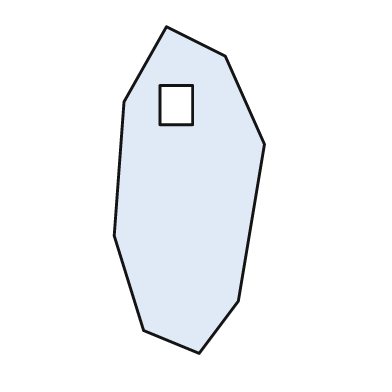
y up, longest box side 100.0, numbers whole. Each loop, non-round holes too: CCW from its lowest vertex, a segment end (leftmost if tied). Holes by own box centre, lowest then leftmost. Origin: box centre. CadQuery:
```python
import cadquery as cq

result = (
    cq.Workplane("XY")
    .moveTo(3.0, -50.0)
    .lineTo(15.0, -34.0)
    .lineTo(23.0, 14.0)
    .lineTo(11.0, 41.0)
    .lineTo(-7.0, 50.0)
    .lineTo(-20.0, 27.0)
    .lineTo(-23.0, -14.0)
    .lineTo(-14.0, -43.0)
    .close()
    .moveTo(-9.0, 20.0)
    .lineTo(1.0, 20.0)
    .lineTo(1.0, 32.0)
    .lineTo(-9.0, 32.0)
    .close()
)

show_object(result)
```